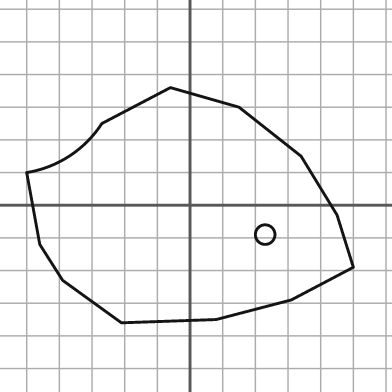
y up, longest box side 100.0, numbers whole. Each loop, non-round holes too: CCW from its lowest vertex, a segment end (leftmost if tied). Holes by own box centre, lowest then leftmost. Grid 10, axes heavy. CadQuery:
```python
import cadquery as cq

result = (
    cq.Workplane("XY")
    .moveTo(-21.0, -36.0)
    .lineTo(8.0, -35.0)
    .lineTo(31.0, -29.0)
    .lineTo(50.0, -19.0)
    .lineTo(45.0, -3.0)
    .lineTo(34.0, 15.0)
    .lineTo(15.0, 30.0)
    .lineTo(-6.0, 36.0)
    .lineTo(-27.0, 25.0)
    .threePointArc((-37.0, 15.0), (-50.0, 10.0))
    .lineTo(-46.0, -12.0)
    .lineTo(-39.0, -23.0)
    .close()
    .moveTo(23.0, -9.0)
    .circle(3.0)
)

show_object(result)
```